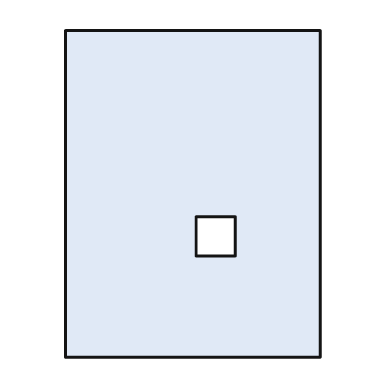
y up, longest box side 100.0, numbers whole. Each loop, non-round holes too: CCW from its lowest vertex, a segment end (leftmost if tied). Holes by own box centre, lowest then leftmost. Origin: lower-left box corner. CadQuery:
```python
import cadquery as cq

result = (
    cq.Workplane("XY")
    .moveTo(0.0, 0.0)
    .lineTo(78.0, 0.0)
    .lineTo(78.0, 100.0)
    .lineTo(0.0, 100.0)
    .close()
    .moveTo(40.0, 31.0)
    .lineTo(52.0, 31.0)
    .lineTo(52.0, 43.0)
    .lineTo(40.0, 43.0)
    .close()
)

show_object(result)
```